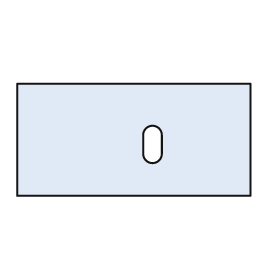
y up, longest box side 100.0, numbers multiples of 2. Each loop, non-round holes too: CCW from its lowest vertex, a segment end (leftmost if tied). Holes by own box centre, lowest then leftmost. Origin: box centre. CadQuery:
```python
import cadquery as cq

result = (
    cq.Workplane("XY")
    .moveTo(-50.0, -24.0)
    .lineTo(50.0, -24.0)
    .lineTo(50.0, 24.0)
    .lineTo(-50.0, 24.0)
    .close()
    .moveTo(4.0, -6.0)
    .threePointArc((8.0, -10.0), (12.0, -6.0))
    .lineTo(12.0, 2.0)
    .threePointArc((8.0, 6.0), (4.0, 2.0))
    .close()
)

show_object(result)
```